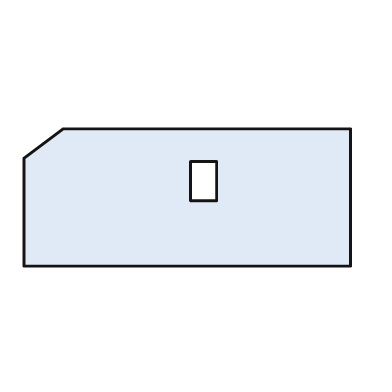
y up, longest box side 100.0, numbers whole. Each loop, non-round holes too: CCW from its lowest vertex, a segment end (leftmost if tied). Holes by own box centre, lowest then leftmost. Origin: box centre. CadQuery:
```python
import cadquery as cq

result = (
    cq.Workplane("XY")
    .moveTo(-50.0, -21.0)
    .lineTo(50.0, -21.0)
    .lineTo(50.0, 21.0)
    .lineTo(-38.0, 21.0)
    .lineTo(-50.0, 12.0)
    .close()
    .moveTo(1.0, -1.0)
    .lineTo(9.0, -1.0)
    .lineTo(9.0, 11.0)
    .lineTo(1.0, 11.0)
    .close()
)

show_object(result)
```